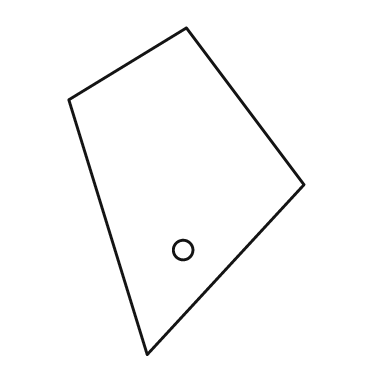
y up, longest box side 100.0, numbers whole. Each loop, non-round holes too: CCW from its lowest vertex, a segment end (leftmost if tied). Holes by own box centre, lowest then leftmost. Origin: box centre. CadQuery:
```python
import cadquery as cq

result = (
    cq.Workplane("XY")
    .moveTo(-12.0, -50.0)
    .lineTo(36.0, 2.0)
    .lineTo(0.0, 50.0)
    .lineTo(-36.0, 28.0)
    .close()
    .moveTo(-1.0, -18.0)
    .circle(3.0)
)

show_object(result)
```